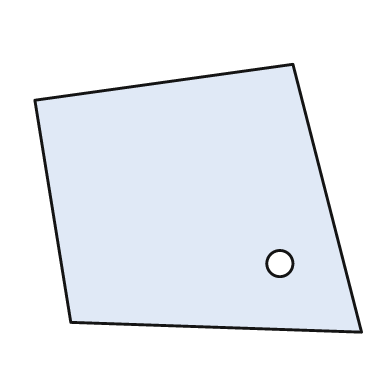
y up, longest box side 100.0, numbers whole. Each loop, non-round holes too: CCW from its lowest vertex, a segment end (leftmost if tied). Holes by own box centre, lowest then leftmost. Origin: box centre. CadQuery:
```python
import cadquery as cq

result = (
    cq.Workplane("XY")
    .moveTo(50.0, -41.0)
    .lineTo(29.0, 41.0)
    .lineTo(-50.0, 30.0)
    .lineTo(-39.0, -38.0)
    .close()
    .moveTo(25.0, -20.0)
    .circle(4.0)
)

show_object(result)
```